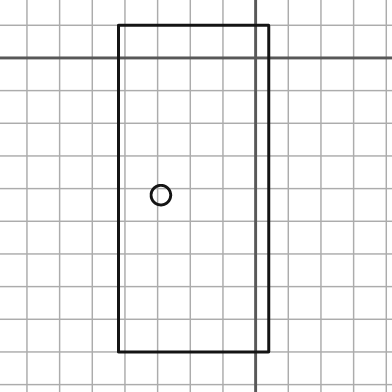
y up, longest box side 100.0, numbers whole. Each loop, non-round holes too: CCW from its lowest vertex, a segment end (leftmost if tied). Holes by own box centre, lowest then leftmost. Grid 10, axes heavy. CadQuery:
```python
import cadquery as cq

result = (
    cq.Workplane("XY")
    .moveTo(-42.0, -90.0)
    .lineTo(4.0, -90.0)
    .lineTo(4.0, 10.0)
    .lineTo(-42.0, 10.0)
    .close()
    .moveTo(-29.0, -42.0)
    .circle(3.0)
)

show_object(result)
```